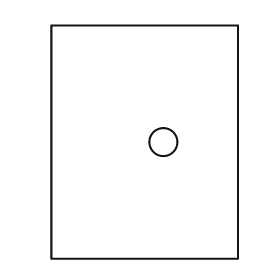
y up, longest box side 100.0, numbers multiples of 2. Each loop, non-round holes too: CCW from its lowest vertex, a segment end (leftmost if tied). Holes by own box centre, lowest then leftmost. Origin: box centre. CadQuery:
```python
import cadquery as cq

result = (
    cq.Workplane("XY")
    .moveTo(-40.0, -50.0)
    .lineTo(40.0, -50.0)
    .lineTo(40.0, 50.0)
    .lineTo(-40.0, 50.0)
    .close()
    .moveTo(8.0, 0.0)
    .circle(6.0)
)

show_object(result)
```